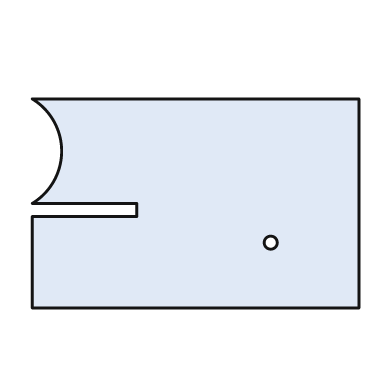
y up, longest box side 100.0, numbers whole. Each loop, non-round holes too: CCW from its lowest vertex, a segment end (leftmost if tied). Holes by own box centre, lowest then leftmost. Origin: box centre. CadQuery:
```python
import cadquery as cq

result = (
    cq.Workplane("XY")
    .moveTo(-50.0, -32.0)
    .lineTo(50.0, -32.0)
    .lineTo(50.0, 32.0)
    .lineTo(-50.0, 32.0)
    .threePointArc((-41.0, 16.0), (-50.0, 0.0))
    .lineTo(-18.0, 0.0)
    .lineTo(-18.0, -4.0)
    .lineTo(-50.0, -4.0)
    .close()
    .moveTo(23.0, -12.0)
    .circle(2.0)
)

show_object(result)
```